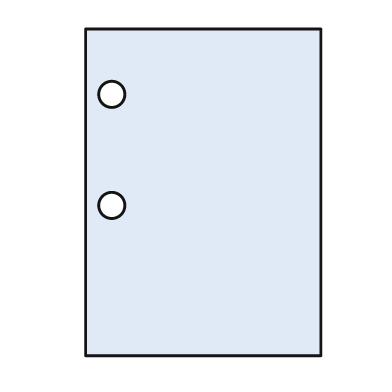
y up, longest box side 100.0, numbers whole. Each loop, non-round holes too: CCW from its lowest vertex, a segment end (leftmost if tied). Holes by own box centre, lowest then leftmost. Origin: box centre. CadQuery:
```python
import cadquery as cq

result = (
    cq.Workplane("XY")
    .moveTo(-36.0, -50.0)
    .lineTo(36.0, -50.0)
    .lineTo(36.0, 50.0)
    .lineTo(-36.0, 50.0)
    .close()
    .moveTo(-28.0, -4.0)
    .circle(4.0)
    .moveTo(-28.0, 30.0)
    .circle(4.0)
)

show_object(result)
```